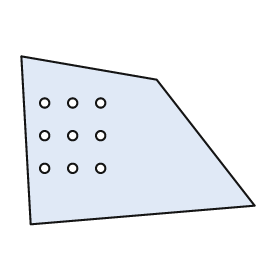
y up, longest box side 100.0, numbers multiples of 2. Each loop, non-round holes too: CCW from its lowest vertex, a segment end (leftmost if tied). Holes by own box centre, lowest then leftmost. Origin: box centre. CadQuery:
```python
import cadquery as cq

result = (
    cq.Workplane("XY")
    .moveTo(-46.0, -36.0)
    .lineTo(50.0, -28.0)
    .lineTo(8.0, 26.0)
    .lineTo(-50.0, 36.0)
    .close()
    .moveTo(-40.0, -12.0)
    .circle(2.0)
    .moveTo(-28.0, -12.0)
    .circle(2.0)
    .moveTo(-16.0, -12.0)
    .circle(2.0)
    .moveTo(-40.0, 2.0)
    .circle(2.0)
    .moveTo(-28.0, 2.0)
    .circle(2.0)
    .moveTo(-16.0, 2.0)
    .circle(2.0)
    .moveTo(-40.0, 16.0)
    .circle(2.0)
    .moveTo(-28.0, 16.0)
    .circle(2.0)
    .moveTo(-16.0, 16.0)
    .circle(2.0)
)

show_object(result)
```